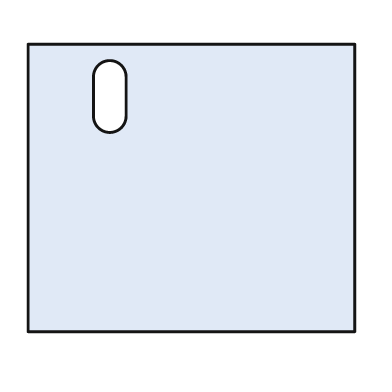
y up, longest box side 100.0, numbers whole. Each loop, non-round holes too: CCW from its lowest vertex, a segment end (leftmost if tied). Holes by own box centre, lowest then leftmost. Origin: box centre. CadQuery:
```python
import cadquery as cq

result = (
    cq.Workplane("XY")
    .moveTo(-50.0, -44.0)
    .lineTo(50.0, -44.0)
    .lineTo(50.0, 44.0)
    .lineTo(-50.0, 44.0)
    .close()
    .moveTo(-30.0, 22.0)
    .threePointArc((-25.0, 17.0), (-20.0, 22.0))
    .lineTo(-20.0, 34.0)
    .threePointArc((-25.0, 39.0), (-30.0, 34.0))
    .close()
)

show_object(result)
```